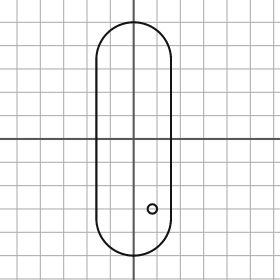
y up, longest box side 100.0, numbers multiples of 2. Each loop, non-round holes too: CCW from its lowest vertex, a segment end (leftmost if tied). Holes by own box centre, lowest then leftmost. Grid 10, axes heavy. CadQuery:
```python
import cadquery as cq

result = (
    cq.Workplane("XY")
    .moveTo(-16.0, -34.0)
    .threePointArc((0.0, -50.0), (16.0, -34.0))
    .lineTo(16.0, 34.0)
    .threePointArc((0.0, 50.0), (-16.0, 34.0))
    .close()
    .moveTo(8.0, -30.0)
    .circle(2.0)
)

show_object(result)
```